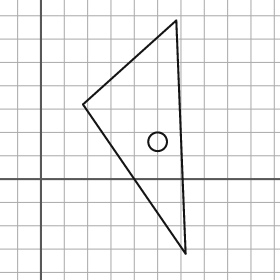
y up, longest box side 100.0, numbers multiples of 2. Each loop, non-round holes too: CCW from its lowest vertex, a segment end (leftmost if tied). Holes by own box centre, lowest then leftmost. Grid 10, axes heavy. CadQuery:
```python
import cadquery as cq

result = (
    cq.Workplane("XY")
    .moveTo(62.0, -32.0)
    .lineTo(58.0, 68.0)
    .lineTo(18.0, 32.0)
    .close()
    .moveTo(50.0, 16.0)
    .circle(4.0)
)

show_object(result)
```